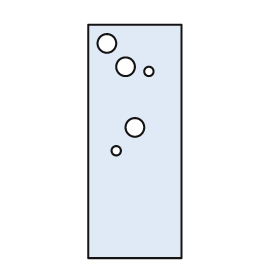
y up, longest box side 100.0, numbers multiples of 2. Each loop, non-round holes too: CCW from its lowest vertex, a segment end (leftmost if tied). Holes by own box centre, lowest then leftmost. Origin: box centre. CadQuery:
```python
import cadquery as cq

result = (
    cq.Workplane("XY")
    .moveTo(-20.0, -50.0)
    .lineTo(20.0, -50.0)
    .lineTo(20.0, 50.0)
    .lineTo(-20.0, 50.0)
    .close()
    .moveTo(-8.0, -4.0)
    .circle(2.0)
    .moveTo(0.0, 6.0)
    .circle(4.0)
    .moveTo(6.0, 30.0)
    .circle(2.0)
    .moveTo(-4.0, 32.0)
    .circle(4.0)
    .moveTo(-12.0, 42.0)
    .circle(4.0)
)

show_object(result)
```